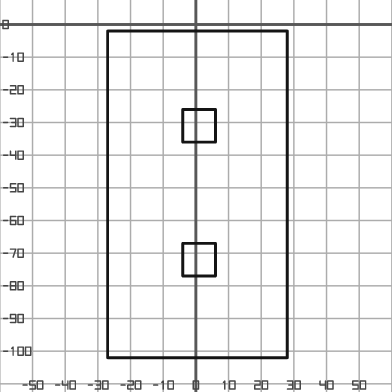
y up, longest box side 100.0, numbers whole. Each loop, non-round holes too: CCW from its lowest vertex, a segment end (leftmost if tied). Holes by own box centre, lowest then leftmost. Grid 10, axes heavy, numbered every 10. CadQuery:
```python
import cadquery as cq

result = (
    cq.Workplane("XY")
    .moveTo(-27.0, -102.0)
    .lineTo(28.0, -102.0)
    .lineTo(28.0, -2.0)
    .lineTo(-27.0, -2.0)
    .close()
    .moveTo(-4.0, -77.0)
    .lineTo(6.0, -77.0)
    .lineTo(6.0, -67.0)
    .lineTo(-4.0, -67.0)
    .close()
    .moveTo(-4.0, -36.0)
    .lineTo(6.0, -36.0)
    .lineTo(6.0, -26.0)
    .lineTo(-4.0, -26.0)
    .close()
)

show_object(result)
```